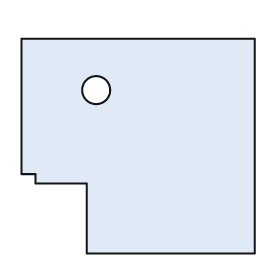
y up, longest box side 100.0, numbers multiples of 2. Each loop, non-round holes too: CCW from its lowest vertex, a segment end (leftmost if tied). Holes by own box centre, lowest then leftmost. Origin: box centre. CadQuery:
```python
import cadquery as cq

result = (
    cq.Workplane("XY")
    .moveTo(-22.0, -46.0)
    .lineTo(50.0, -46.0)
    .lineTo(50.0, 46.0)
    .lineTo(-50.0, 46.0)
    .lineTo(-50.0, -12.0)
    .lineTo(-44.0, -12.0)
    .lineTo(-44.0, -16.0)
    .lineTo(-22.0, -16.0)
    .close()
    .moveTo(-18.0, 24.0)
    .circle(6.0)
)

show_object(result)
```